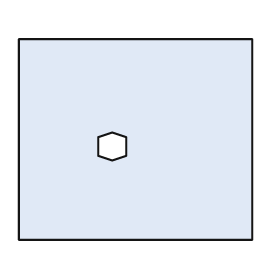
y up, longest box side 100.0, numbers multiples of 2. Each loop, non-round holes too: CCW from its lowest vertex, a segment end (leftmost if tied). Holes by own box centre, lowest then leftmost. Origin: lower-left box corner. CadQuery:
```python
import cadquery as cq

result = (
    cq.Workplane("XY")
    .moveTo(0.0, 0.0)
    .lineTo(100.0, 0.0)
    .lineTo(100.0, 86.0)
    .lineTo(0.0, 86.0)
    .close()
    .moveTo(40.0, 34.0)
    .lineTo(46.0, 36.0)
    .lineTo(46.0, 44.0)
    .lineTo(40.0, 46.0)
    .lineTo(34.0, 44.0)
    .lineTo(34.0, 36.0)
    .close()
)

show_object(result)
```